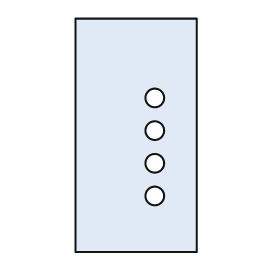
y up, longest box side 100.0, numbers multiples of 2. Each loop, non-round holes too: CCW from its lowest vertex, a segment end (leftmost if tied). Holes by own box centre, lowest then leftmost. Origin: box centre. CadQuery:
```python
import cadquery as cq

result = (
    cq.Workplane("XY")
    .moveTo(-26.0, -50.0)
    .lineTo(26.0, -50.0)
    .lineTo(26.0, 50.0)
    .lineTo(-26.0, 50.0)
    .close()
    .moveTo(8.0, -26.0)
    .circle(4.0)
    .moveTo(8.0, -12.0)
    .circle(4.0)
    .moveTo(8.0, 2.0)
    .circle(4.0)
    .moveTo(8.0, 16.0)
    .circle(4.0)
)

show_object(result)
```